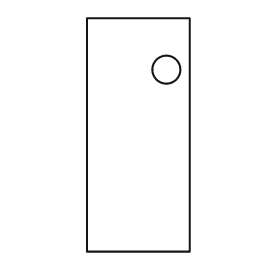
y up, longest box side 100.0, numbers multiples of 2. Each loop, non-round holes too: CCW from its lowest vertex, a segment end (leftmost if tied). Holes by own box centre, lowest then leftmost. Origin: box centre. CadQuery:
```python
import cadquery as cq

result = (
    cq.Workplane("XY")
    .moveTo(-22.0, -50.0)
    .lineTo(22.0, -50.0)
    .lineTo(22.0, 50.0)
    .lineTo(-22.0, 50.0)
    .close()
    .moveTo(12.0, 28.0)
    .circle(6.0)
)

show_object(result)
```